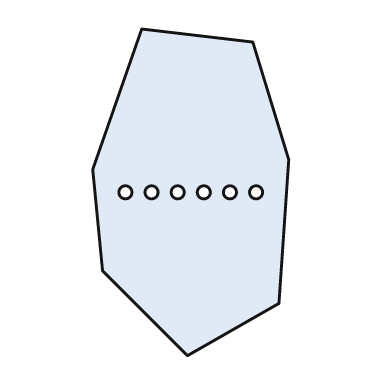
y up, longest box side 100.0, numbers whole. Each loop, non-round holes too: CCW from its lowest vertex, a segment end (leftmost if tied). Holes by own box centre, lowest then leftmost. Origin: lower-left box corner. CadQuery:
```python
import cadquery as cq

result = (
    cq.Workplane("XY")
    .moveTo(29.0, 0.0)
    .lineTo(57.0, 16.0)
    .lineTo(60.0, 60.0)
    .lineTo(49.0, 96.0)
    .lineTo(15.0, 100.0)
    .lineTo(0.0, 57.0)
    .lineTo(3.0, 26.0)
    .close()
    .moveTo(10.0, 50.0)
    .circle(2.0)
    .moveTo(18.0, 50.0)
    .circle(2.0)
    .moveTo(26.0, 50.0)
    .circle(2.0)
    .moveTo(34.0, 50.0)
    .circle(2.0)
    .moveTo(42.0, 50.0)
    .circle(2.0)
    .moveTo(50.0, 50.0)
    .circle(2.0)
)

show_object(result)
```